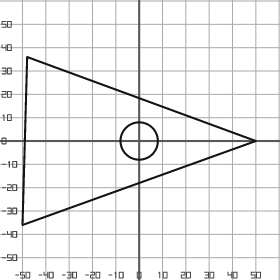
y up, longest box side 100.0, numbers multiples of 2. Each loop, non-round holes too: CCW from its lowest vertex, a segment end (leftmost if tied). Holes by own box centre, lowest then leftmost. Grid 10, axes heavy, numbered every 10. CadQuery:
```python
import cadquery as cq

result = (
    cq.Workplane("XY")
    .moveTo(-50.0, -36.0)
    .lineTo(50.0, 0.0)
    .lineTo(-48.0, 36.0)
    .close()
    .moveTo(0.0, 0.0)
    .circle(8.0)
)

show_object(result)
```